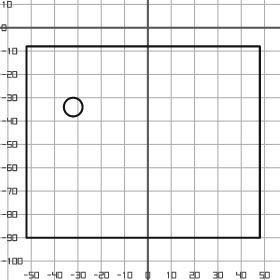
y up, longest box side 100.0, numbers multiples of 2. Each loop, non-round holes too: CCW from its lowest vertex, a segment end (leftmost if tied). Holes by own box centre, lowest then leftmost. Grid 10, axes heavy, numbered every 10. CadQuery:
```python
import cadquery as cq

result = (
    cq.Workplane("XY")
    .moveTo(-52.0, -90.0)
    .lineTo(48.0, -90.0)
    .lineTo(48.0, -8.0)
    .lineTo(-52.0, -8.0)
    .close()
    .moveTo(-32.0, -34.0)
    .circle(4.0)
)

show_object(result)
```